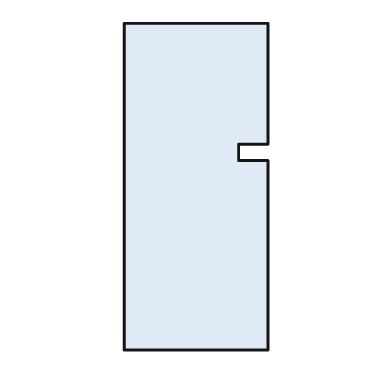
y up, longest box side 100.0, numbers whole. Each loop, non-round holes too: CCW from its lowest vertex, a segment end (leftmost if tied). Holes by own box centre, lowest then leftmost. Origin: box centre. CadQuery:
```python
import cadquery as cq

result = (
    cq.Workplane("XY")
    .moveTo(-22.0, -50.0)
    .lineTo(22.0, -50.0)
    .lineTo(22.0, 8.0)
    .lineTo(13.0, 8.0)
    .lineTo(13.0, 13.0)
    .lineTo(22.0, 13.0)
    .lineTo(22.0, 50.0)
    .lineTo(-22.0, 50.0)
    .close()
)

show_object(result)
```